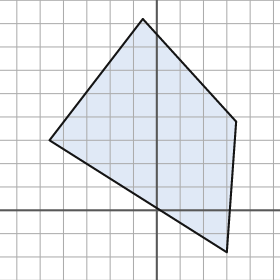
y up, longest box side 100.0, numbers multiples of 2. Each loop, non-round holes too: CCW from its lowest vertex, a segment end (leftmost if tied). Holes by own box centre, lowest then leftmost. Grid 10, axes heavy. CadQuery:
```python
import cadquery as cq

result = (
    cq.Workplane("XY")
    .moveTo(30.0, -18.0)
    .lineTo(34.0, 38.0)
    .lineTo(-6.0, 82.0)
    .lineTo(-46.0, 30.0)
    .close()
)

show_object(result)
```